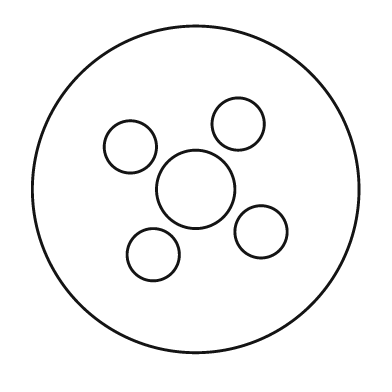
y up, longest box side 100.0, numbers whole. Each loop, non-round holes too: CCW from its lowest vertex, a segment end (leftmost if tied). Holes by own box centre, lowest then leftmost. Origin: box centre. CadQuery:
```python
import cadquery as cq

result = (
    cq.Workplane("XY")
    .moveTo(0.0, 0.0)
    .circle(50.0)
    .moveTo(-13.0, -20.0)
    .circle(8.0)
    .moveTo(20.0, -13.0)
    .circle(8.0)
    .moveTo(0.0, 0.0)
    .circle(12.0)
    .moveTo(-20.0, 13.0)
    .circle(8.0)
    .moveTo(13.0, 20.0)
    .circle(8.0)
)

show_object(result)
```